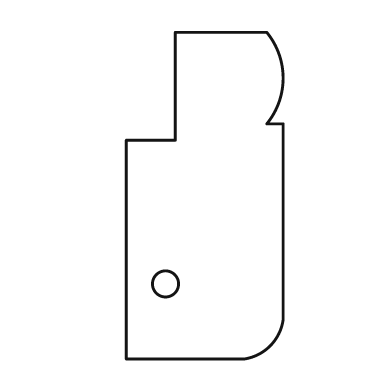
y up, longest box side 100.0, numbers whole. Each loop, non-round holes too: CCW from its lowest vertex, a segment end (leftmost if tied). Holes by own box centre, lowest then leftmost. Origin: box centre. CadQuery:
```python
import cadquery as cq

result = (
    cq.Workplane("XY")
    .moveTo(-24.0, -50.0)
    .lineTo(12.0, -50.0)
    .threePointArc((20.0, -46.0), (24.0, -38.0))
    .lineTo(24.0, 22.0)
    .lineTo(19.0, 22.0)
    .threePointArc((24.0, 36.0), (19.0, 50.0))
    .lineTo(-9.0, 50.0)
    .lineTo(-9.0, 17.0)
    .lineTo(-24.0, 17.0)
    .close()
    .moveTo(-12.0, -27.0)
    .circle(4.0)
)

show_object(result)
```